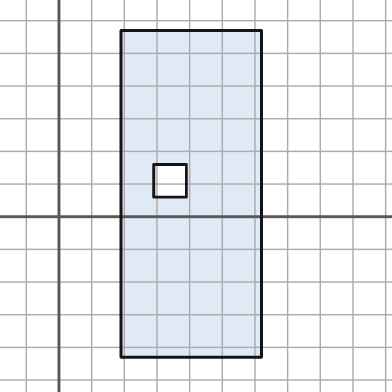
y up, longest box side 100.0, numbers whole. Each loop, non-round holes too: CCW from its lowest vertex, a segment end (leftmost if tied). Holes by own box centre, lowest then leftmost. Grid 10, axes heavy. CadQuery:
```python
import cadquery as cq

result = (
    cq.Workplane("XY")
    .moveTo(19.0, -43.0)
    .lineTo(62.0, -43.0)
    .lineTo(62.0, 57.0)
    .lineTo(19.0, 57.0)
    .close()
    .moveTo(29.0, 6.0)
    .lineTo(39.0, 6.0)
    .lineTo(39.0, 16.0)
    .lineTo(29.0, 16.0)
    .close()
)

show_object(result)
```